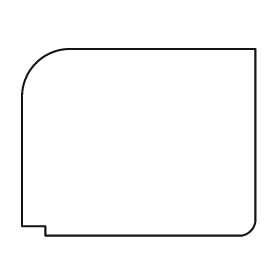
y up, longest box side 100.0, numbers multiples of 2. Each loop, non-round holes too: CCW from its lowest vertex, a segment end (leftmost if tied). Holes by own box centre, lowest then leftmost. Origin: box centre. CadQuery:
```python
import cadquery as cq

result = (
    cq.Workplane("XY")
    .moveTo(-40.0, -40.0)
    .lineTo(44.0, -40.0)
    .threePointArc((48.0, -38.0), (50.0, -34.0))
    .lineTo(50.0, 40.0)
    .lineTo(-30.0, 40.0)
    .threePointArc((-44.0, 34.0), (-50.0, 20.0))
    .lineTo(-50.0, -36.0)
    .lineTo(-40.0, -36.0)
    .close()
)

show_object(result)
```